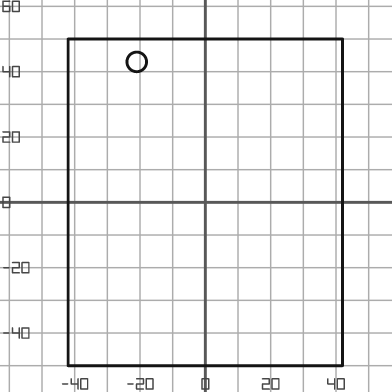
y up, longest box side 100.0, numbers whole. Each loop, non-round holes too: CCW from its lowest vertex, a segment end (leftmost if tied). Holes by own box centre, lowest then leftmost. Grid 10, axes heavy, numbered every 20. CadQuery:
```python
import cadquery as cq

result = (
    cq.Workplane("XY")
    .moveTo(-42.0, -50.0)
    .lineTo(42.0, -50.0)
    .lineTo(42.0, 50.0)
    .lineTo(-42.0, 50.0)
    .close()
    .moveTo(-21.0, 43.0)
    .circle(3.0)
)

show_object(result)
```